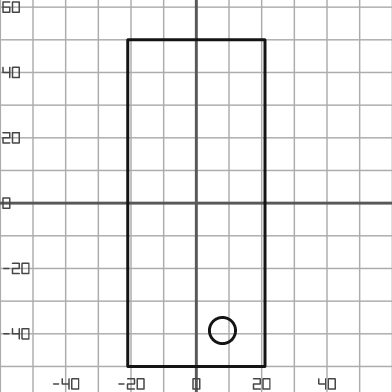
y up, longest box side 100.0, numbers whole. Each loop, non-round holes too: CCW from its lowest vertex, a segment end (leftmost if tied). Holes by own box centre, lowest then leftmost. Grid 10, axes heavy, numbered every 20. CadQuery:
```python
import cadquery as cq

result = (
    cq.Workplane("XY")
    .moveTo(-21.0, -50.0)
    .lineTo(21.0, -50.0)
    .lineTo(21.0, 50.0)
    .lineTo(-21.0, 50.0)
    .close()
    .moveTo(8.0, -39.0)
    .circle(4.0)
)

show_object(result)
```